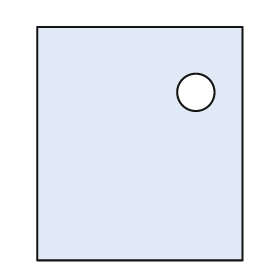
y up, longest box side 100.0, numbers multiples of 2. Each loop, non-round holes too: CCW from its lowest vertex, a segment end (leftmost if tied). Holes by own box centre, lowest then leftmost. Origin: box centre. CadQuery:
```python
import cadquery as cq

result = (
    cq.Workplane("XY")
    .moveTo(-44.0, -50.0)
    .lineTo(44.0, -50.0)
    .lineTo(44.0, 50.0)
    .lineTo(-44.0, 50.0)
    .close()
    .moveTo(24.0, 22.0)
    .circle(8.0)
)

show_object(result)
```